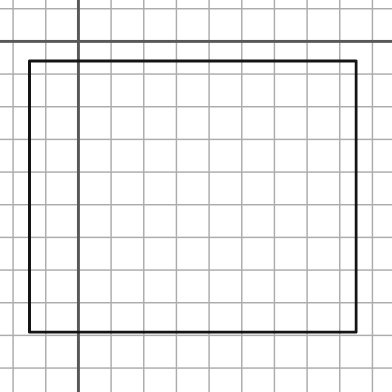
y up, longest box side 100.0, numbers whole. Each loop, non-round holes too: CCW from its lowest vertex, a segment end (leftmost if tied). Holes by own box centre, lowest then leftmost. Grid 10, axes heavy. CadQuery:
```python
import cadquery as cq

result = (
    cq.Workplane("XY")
    .moveTo(-15.0, -89.0)
    .lineTo(85.0, -89.0)
    .lineTo(85.0, -6.0)
    .lineTo(-15.0, -6.0)
    .close()
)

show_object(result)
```